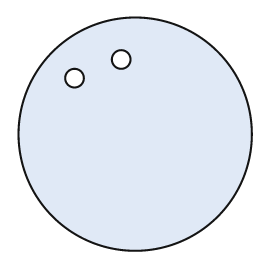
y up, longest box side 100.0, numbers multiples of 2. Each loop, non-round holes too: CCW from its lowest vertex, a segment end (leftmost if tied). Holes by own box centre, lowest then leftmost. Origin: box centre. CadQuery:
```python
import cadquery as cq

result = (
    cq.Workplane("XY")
    .moveTo(0.0, 0.0)
    .circle(50.0)
    .moveTo(-26.0, 24.0)
    .circle(4.0)
    .moveTo(-6.0, 32.0)
    .circle(4.0)
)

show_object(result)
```